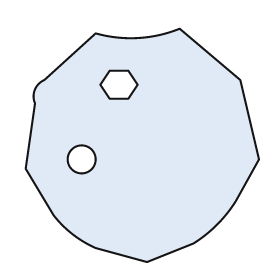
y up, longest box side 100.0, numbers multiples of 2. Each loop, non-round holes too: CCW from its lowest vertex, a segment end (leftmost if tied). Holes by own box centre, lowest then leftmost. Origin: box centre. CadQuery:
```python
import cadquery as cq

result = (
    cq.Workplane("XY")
    .moveTo(2.0, -50.0)
    .lineTo(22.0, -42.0)
    .threePointArc((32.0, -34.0), (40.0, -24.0))
    .lineTo(50.0, -6.0)
    .lineTo(42.0, 28.0)
    .lineTo(16.0, 50.0)
    .threePointArc((-2.0, 46.0), (-20.0, 48.0))
    .lineTo(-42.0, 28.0)
    .threePointArc((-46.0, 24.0), (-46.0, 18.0))
    .lineTo(-50.0, -10.0)
    .lineTo(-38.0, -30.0)
    .threePointArc((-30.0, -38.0), (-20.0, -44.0))
    .close()
    .moveTo(-26.0, -6.0)
    .circle(6.0)
    .moveTo(-14.0, 20.0)
    .lineTo(-6.0, 20.0)
    .lineTo(-2.0, 26.0)
    .lineTo(-6.0, 32.0)
    .lineTo(-14.0, 32.0)
    .lineTo(-18.0, 26.0)
    .close()
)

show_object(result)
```